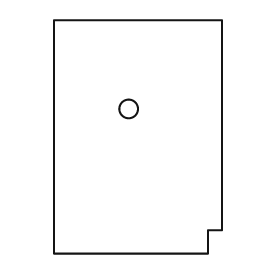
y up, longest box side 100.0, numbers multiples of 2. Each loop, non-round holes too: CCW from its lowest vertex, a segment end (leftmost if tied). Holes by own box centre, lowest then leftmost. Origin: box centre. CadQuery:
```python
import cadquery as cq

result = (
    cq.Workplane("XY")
    .moveTo(-36.0, -50.0)
    .lineTo(30.0, -50.0)
    .lineTo(30.0, -40.0)
    .lineTo(36.0, -40.0)
    .lineTo(36.0, 50.0)
    .lineTo(-36.0, 50.0)
    .close()
    .moveTo(-4.0, 12.0)
    .circle(4.0)
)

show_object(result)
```